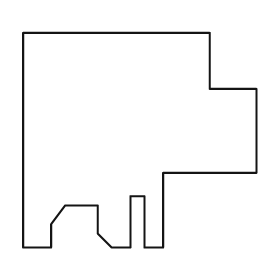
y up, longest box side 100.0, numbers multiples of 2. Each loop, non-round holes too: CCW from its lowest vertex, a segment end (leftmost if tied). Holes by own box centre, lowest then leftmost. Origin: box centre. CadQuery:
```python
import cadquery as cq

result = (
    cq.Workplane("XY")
    .moveTo(-50.0, -46.0)
    .lineTo(-38.0, -46.0)
    .lineTo(-38.0, -36.0)
    .lineTo(-32.0, -28.0)
    .lineTo(-18.0, -28.0)
    .lineTo(-18.0, -40.0)
    .lineTo(-12.0, -46.0)
    .lineTo(-4.0, -46.0)
    .lineTo(-4.0, -24.0)
    .lineTo(2.0, -24.0)
    .lineTo(2.0, -46.0)
    .lineTo(10.0, -46.0)
    .lineTo(10.0, -14.0)
    .lineTo(50.0, -14.0)
    .lineTo(50.0, 22.0)
    .lineTo(30.0, 22.0)
    .lineTo(30.0, 46.0)
    .lineTo(-50.0, 46.0)
    .close()
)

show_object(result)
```